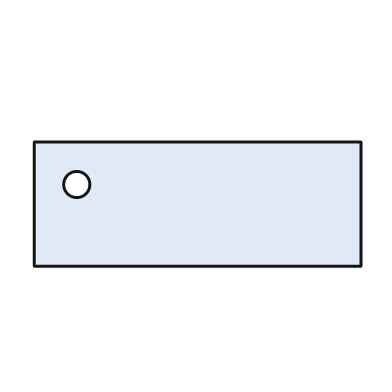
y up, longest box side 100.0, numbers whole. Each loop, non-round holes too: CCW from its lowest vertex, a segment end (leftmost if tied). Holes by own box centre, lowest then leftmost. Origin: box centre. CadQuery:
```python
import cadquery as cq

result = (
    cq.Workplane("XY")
    .moveTo(-50.0, -19.0)
    .lineTo(50.0, -19.0)
    .lineTo(50.0, 19.0)
    .lineTo(-50.0, 19.0)
    .close()
    .moveTo(-37.0, 6.0)
    .circle(4.0)
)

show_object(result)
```